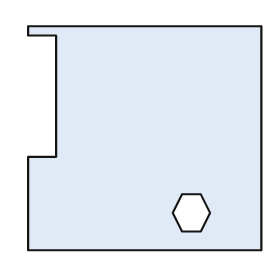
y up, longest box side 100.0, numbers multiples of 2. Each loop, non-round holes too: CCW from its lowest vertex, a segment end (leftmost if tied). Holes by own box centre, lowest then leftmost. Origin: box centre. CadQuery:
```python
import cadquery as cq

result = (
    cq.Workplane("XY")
    .moveTo(-50.0, -48.0)
    .lineTo(50.0, -48.0)
    .lineTo(50.0, 48.0)
    .lineTo(-50.0, 48.0)
    .lineTo(-50.0, 44.0)
    .lineTo(-38.0, 44.0)
    .lineTo(-38.0, -8.0)
    .lineTo(-50.0, -8.0)
    .close()
    .moveTo(16.0, -40.0)
    .lineTo(24.0, -40.0)
    .lineTo(28.0, -32.0)
    .lineTo(24.0, -24.0)
    .lineTo(16.0, -24.0)
    .lineTo(12.0, -32.0)
    .close()
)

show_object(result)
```